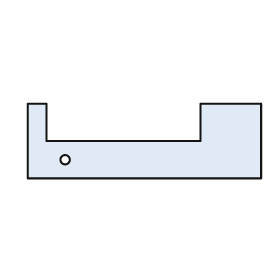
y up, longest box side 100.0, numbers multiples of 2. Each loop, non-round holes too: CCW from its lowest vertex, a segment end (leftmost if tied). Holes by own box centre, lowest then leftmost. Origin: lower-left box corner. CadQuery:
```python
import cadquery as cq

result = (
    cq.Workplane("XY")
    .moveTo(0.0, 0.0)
    .lineTo(100.0, 0.0)
    .lineTo(100.0, 32.0)
    .lineTo(74.0, 32.0)
    .lineTo(74.0, 16.0)
    .lineTo(8.0, 16.0)
    .lineTo(8.0, 32.0)
    .lineTo(0.0, 32.0)
    .close()
    .moveTo(16.0, 8.0)
    .circle(2.0)
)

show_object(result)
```